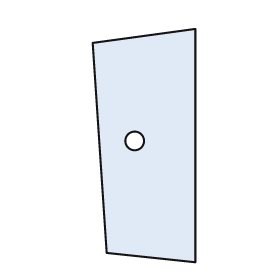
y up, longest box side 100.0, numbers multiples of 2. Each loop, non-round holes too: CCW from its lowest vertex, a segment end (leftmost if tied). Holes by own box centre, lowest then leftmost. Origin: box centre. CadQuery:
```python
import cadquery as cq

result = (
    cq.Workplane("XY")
    .moveTo(22.0, -50.0)
    .lineTo(22.0, 50.0)
    .lineTo(-22.0, 44.0)
    .lineTo(-16.0, -46.0)
    .close()
    .moveTo(-4.0, 2.0)
    .circle(4.0)
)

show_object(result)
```